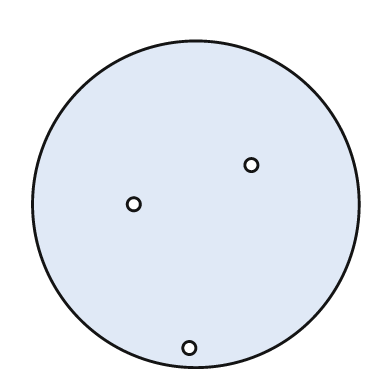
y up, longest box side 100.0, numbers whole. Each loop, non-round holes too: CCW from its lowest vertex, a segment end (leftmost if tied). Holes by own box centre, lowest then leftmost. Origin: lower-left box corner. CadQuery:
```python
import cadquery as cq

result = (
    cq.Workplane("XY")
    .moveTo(50.0, 50.0)
    .circle(50.0)
    .moveTo(48.0, 6.0)
    .circle(2.0)
    .moveTo(31.0, 50.0)
    .circle(2.0)
    .moveTo(67.0, 62.0)
    .circle(2.0)
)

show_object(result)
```